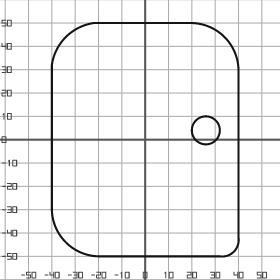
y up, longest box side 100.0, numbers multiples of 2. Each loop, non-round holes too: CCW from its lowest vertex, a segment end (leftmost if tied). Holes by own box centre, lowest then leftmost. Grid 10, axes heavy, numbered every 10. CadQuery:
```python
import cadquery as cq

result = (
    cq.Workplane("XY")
    .moveTo(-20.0, -50.0)
    .lineTo(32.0, -50.0)
    .threePointArc((38.0, -48.0), (40.0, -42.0))
    .lineTo(40.0, 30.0)
    .threePointArc((34.0, 44.0), (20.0, 50.0))
    .lineTo(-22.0, 50.0)
    .threePointArc((-34.0, 44.0), (-40.0, 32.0))
    .lineTo(-40.0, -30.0)
    .threePointArc((-34.0, -44.0), (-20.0, -50.0))
    .close()
    .moveTo(26.0, 4.0)
    .circle(6.0)
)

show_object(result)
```